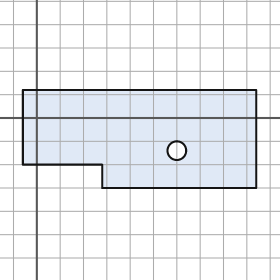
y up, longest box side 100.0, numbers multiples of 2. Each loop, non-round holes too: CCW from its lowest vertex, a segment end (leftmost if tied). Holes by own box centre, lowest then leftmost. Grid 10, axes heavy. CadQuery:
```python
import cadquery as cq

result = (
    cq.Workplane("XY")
    .moveTo(28.0, -30.0)
    .lineTo(94.0, -30.0)
    .lineTo(94.0, 12.0)
    .lineTo(-6.0, 12.0)
    .lineTo(-6.0, -20.0)
    .lineTo(28.0, -20.0)
    .close()
    .moveTo(60.0, -14.0)
    .circle(4.0)
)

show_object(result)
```